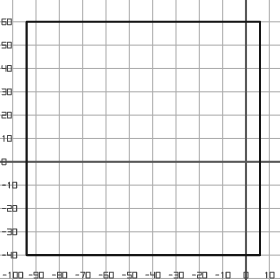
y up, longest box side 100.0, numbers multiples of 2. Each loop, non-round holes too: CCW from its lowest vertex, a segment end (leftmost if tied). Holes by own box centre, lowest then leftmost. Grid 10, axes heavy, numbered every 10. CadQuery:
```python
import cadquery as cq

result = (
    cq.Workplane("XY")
    .moveTo(-94.0, -40.0)
    .lineTo(6.0, -40.0)
    .lineTo(6.0, 60.0)
    .lineTo(-94.0, 60.0)
    .close()
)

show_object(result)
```